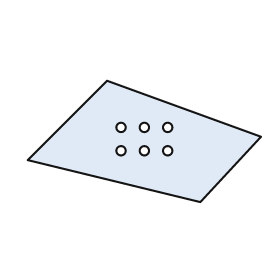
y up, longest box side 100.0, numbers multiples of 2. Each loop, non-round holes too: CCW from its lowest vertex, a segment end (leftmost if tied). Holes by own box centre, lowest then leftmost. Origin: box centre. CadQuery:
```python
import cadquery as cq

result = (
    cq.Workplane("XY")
    .moveTo(24.0, -26.0)
    .lineTo(50.0, 2.0)
    .lineTo(-16.0, 26.0)
    .lineTo(-50.0, -8.0)
    .close()
    .moveTo(-10.0, -4.0)
    .circle(2.0)
    .moveTo(0.0, -4.0)
    .circle(2.0)
    .moveTo(10.0, -4.0)
    .circle(2.0)
    .moveTo(-10.0, 6.0)
    .circle(2.0)
    .moveTo(0.0, 6.0)
    .circle(2.0)
    .moveTo(10.0, 6.0)
    .circle(2.0)
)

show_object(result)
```